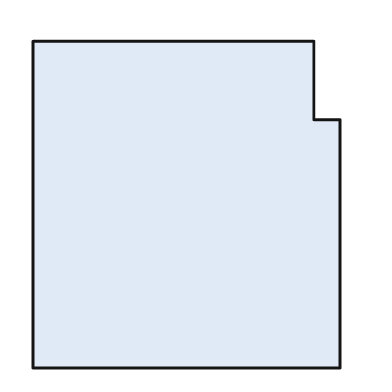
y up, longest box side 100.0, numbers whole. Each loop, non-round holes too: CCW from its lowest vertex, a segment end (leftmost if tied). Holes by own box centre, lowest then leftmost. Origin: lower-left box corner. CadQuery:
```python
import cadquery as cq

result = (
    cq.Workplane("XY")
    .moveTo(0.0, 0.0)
    .lineTo(94.0, 0.0)
    .lineTo(94.0, 76.0)
    .lineTo(86.0, 76.0)
    .lineTo(86.0, 100.0)
    .lineTo(0.0, 100.0)
    .close()
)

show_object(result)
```